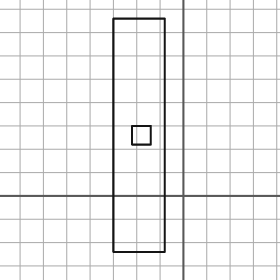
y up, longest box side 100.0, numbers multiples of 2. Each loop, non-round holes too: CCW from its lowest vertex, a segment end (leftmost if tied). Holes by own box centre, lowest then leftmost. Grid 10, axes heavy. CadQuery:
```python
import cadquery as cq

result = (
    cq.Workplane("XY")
    .moveTo(-30.0, -24.0)
    .lineTo(-8.0, -24.0)
    .lineTo(-8.0, 76.0)
    .lineTo(-30.0, 76.0)
    .close()
    .moveTo(-22.0, 22.0)
    .lineTo(-14.0, 22.0)
    .lineTo(-14.0, 30.0)
    .lineTo(-22.0, 30.0)
    .close()
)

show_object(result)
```